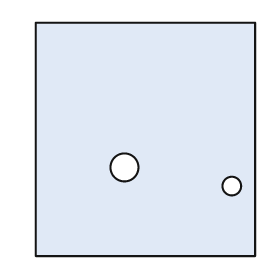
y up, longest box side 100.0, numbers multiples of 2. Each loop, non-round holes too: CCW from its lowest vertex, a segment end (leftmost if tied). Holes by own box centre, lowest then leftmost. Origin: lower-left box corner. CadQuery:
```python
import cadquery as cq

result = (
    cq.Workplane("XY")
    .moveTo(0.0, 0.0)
    .lineTo(94.0, 0.0)
    .lineTo(94.0, 100.0)
    .lineTo(0.0, 100.0)
    .close()
    .moveTo(84.0, 30.0)
    .circle(4.0)
    .moveTo(38.0, 38.0)
    .circle(6.0)
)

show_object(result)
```